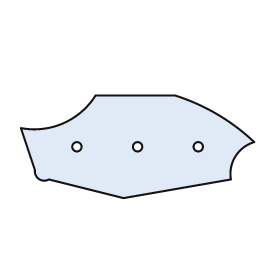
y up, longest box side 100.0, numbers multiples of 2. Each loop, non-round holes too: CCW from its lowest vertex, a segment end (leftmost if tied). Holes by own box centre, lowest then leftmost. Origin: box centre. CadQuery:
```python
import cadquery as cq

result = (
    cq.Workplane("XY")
    .moveTo(-6.0, -22.0)
    .lineTo(40.0, -14.0)
    .threePointArc((42.0, -4.0), (50.0, 2.0))
    .threePointArc((34.0, 14.0), (16.0, 22.0))
    .lineTo(-18.0, 22.0)
    .threePointArc((-32.0, 10.0), (-50.0, 8.0))
    .lineTo(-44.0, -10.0)
    .threePointArc((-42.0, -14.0), (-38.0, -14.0))
    .close()
    .moveTo(-26.0, 0.0)
    .circle(2.0)
    .moveTo(0.0, 0.0)
    .circle(2.0)
    .moveTo(26.0, 0.0)
    .circle(2.0)
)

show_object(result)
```